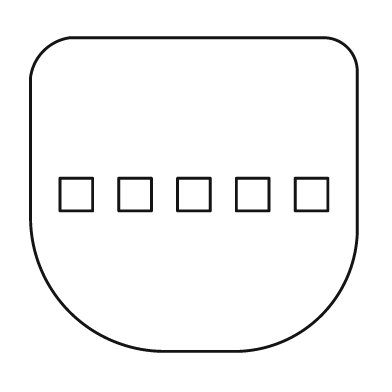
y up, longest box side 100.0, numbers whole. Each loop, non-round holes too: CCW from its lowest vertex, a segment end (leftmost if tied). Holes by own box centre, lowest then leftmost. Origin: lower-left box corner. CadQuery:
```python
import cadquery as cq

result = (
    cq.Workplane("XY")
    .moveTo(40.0, 0.0)
    .lineTo(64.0, 0.0)
    .threePointArc((89.0, 11.0), (100.0, 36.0))
    .lineTo(100.0, 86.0)
    .threePointArc((97.0, 93.0), (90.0, 96.0))
    .lineTo(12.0, 96.0)
    .threePointArc((4.0, 92.0), (0.0, 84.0))
    .lineTo(0.0, 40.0)
    .threePointArc((12.0, 12.0), (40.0, 0.0))
    .close()
    .moveTo(9.0, 43.0)
    .lineTo(19.0, 43.0)
    .lineTo(19.0, 53.0)
    .lineTo(9.0, 53.0)
    .close()
    .moveTo(27.0, 43.0)
    .lineTo(37.0, 43.0)
    .lineTo(37.0, 53.0)
    .lineTo(27.0, 53.0)
    .close()
    .moveTo(45.0, 43.0)
    .lineTo(55.0, 43.0)
    .lineTo(55.0, 53.0)
    .lineTo(45.0, 53.0)
    .close()
    .moveTo(63.0, 43.0)
    .lineTo(73.0, 43.0)
    .lineTo(73.0, 53.0)
    .lineTo(63.0, 53.0)
    .close()
    .moveTo(81.0, 43.0)
    .lineTo(91.0, 43.0)
    .lineTo(91.0, 53.0)
    .lineTo(81.0, 53.0)
    .close()
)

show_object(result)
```